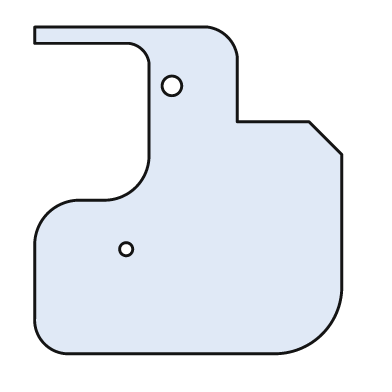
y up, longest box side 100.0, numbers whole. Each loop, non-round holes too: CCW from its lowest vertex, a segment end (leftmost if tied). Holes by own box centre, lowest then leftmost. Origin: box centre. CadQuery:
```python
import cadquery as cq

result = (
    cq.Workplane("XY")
    .moveTo(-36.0, -50.0)
    .lineTo(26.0, -50.0)
    .threePointArc((41.0, -44.0), (47.0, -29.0))
    .lineTo(47.0, 11.0)
    .lineTo(37.0, 21.0)
    .lineTo(15.0, 21.0)
    .lineTo(15.0, 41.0)
    .threePointArc((12.0, 47.0), (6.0, 50.0))
    .lineTo(-47.0, 50.0)
    .lineTo(-47.0, 45.0)
    .lineTo(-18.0, 45.0)
    .threePointArc((-14.0, 43.0), (-12.0, 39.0))
    .lineTo(-12.0, 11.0)
    .threePointArc((-16.0, 1.0), (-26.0, -3.0))
    .lineTo(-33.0, -3.0)
    .threePointArc((-43.0, -7.0), (-47.0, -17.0))
    .lineTo(-47.0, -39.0)
    .threePointArc((-44.0, -47.0), (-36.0, -50.0))
    .close()
    .moveTo(-19.0, -18.0)
    .circle(2.0)
    .moveTo(-5.0, 32.0)
    .circle(3.0)
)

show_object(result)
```